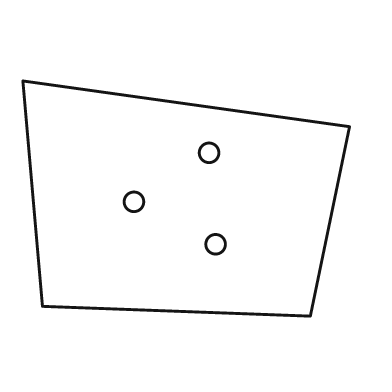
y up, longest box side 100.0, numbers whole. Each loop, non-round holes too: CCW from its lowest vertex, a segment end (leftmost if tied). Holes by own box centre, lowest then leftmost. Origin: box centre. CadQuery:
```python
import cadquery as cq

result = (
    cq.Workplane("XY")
    .moveTo(38.0, -36.0)
    .lineTo(50.0, 22.0)
    .lineTo(-50.0, 36.0)
    .lineTo(-44.0, -33.0)
    .close()
    .moveTo(9.0, -14.0)
    .circle(3.0)
    .moveTo(-16.0, -1.0)
    .circle(3.0)
    .moveTo(7.0, 14.0)
    .circle(3.0)
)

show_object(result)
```